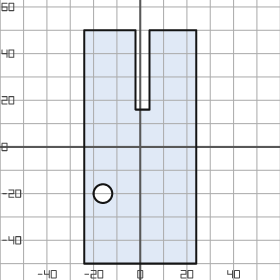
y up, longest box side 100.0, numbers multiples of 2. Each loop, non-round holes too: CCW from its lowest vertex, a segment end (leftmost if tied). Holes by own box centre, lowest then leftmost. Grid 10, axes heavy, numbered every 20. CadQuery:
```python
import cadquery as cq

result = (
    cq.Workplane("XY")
    .moveTo(-24.0, -50.0)
    .lineTo(24.0, -50.0)
    .lineTo(24.0, 50.0)
    .lineTo(4.0, 50.0)
    .lineTo(4.0, 16.0)
    .lineTo(-2.0, 16.0)
    .lineTo(-2.0, 50.0)
    .lineTo(-24.0, 50.0)
    .close()
    .moveTo(-16.0, -20.0)
    .circle(4.0)
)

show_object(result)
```